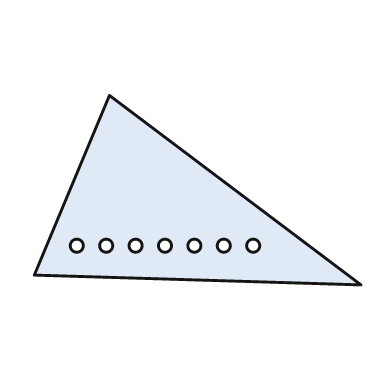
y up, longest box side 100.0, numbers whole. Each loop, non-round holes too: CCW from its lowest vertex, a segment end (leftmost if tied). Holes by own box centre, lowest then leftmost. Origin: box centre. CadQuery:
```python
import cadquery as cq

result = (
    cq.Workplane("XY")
    .moveTo(50.0, -29.0)
    .lineTo(-27.0, 29.0)
    .lineTo(-50.0, -26.0)
    .close()
    .moveTo(-37.0, -17.0)
    .circle(2.0)
    .moveTo(-28.0, -17.0)
    .circle(2.0)
    .moveTo(-19.0, -17.0)
    .circle(2.0)
    .moveTo(-10.0, -17.0)
    .circle(2.0)
    .moveTo(-1.0, -17.0)
    .circle(2.0)
    .moveTo(8.0, -17.0)
    .circle(2.0)
    .moveTo(17.0, -17.0)
    .circle(2.0)
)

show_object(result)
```